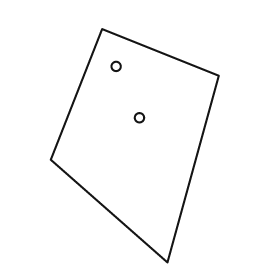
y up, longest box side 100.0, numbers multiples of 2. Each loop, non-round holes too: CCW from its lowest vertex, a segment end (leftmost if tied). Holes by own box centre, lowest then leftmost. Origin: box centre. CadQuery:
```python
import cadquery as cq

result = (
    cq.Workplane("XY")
    .moveTo(14.0, -50.0)
    .lineTo(36.0, 30.0)
    .lineTo(-14.0, 50.0)
    .lineTo(-36.0, -6.0)
    .close()
    .moveTo(2.0, 12.0)
    .circle(2.0)
    .moveTo(-8.0, 34.0)
    .circle(2.0)
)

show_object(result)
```